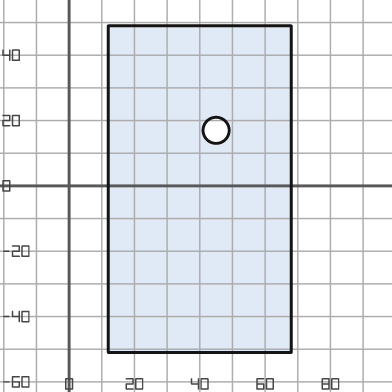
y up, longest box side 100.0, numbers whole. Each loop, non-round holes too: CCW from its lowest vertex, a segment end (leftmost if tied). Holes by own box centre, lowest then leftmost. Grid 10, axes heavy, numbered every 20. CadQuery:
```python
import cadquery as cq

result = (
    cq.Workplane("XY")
    .moveTo(12.0, -51.0)
    .lineTo(68.0, -51.0)
    .lineTo(68.0, 49.0)
    .lineTo(12.0, 49.0)
    .close()
    .moveTo(45.0, 17.0)
    .circle(4.0)
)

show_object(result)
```